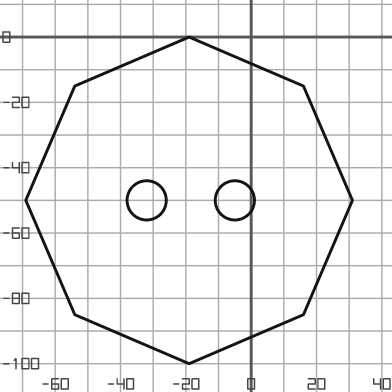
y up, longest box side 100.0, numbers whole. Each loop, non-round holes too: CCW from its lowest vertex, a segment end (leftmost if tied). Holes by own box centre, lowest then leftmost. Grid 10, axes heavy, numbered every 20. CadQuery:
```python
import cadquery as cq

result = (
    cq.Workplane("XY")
    .moveTo(-19.0, -100.0)
    .lineTo(16.0, -85.0)
    .lineTo(31.0, -50.0)
    .lineTo(16.0, -15.0)
    .lineTo(-19.0, 0.0)
    .lineTo(-54.0, -15.0)
    .lineTo(-69.0, -50.0)
    .lineTo(-54.0, -85.0)
    .close()
    .moveTo(-32.0, -50.0)
    .circle(6.0)
    .moveTo(-5.0, -50.0)
    .circle(6.0)
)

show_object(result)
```